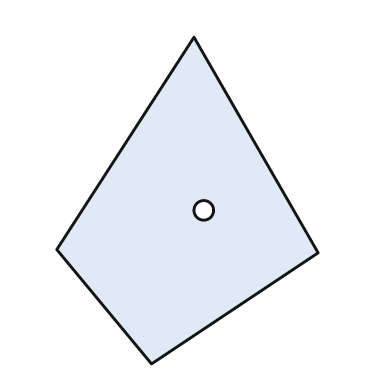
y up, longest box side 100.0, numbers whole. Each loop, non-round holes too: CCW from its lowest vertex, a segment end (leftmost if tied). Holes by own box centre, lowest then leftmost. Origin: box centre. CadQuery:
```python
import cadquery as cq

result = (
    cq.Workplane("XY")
    .moveTo(-11.0, -50.0)
    .lineTo(40.0, -16.0)
    .lineTo(2.0, 50.0)
    .lineTo(-40.0, -15.0)
    .close()
    .moveTo(5.0, -3.0)
    .circle(3.0)
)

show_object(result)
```